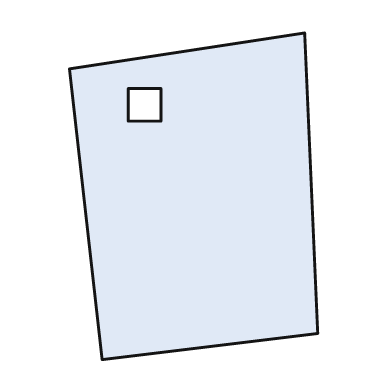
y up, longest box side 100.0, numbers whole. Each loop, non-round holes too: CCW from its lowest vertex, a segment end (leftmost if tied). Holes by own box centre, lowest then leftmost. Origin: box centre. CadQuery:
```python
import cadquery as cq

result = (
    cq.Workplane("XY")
    .moveTo(-28.0, -50.0)
    .lineTo(38.0, -42.0)
    .lineTo(34.0, 50.0)
    .lineTo(-38.0, 39.0)
    .close()
    .moveTo(-20.0, 23.0)
    .lineTo(-10.0, 23.0)
    .lineTo(-10.0, 33.0)
    .lineTo(-20.0, 33.0)
    .close()
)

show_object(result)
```